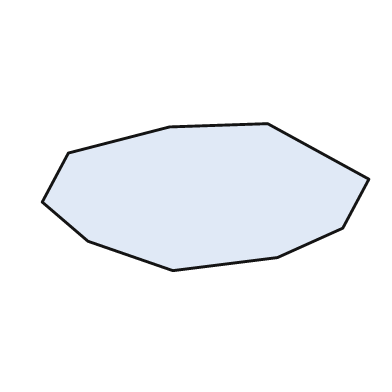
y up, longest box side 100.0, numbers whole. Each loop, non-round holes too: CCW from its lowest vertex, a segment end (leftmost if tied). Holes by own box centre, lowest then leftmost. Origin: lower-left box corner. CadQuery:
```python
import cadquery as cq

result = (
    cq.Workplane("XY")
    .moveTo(40.0, 0.0)
    .lineTo(72.0, 4.0)
    .lineTo(92.0, 13.0)
    .lineTo(100.0, 28.0)
    .lineTo(69.0, 45.0)
    .lineTo(39.0, 44.0)
    .lineTo(8.0, 36.0)
    .lineTo(0.0, 21.0)
    .lineTo(14.0, 9.0)
    .close()
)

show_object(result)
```